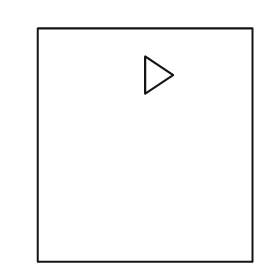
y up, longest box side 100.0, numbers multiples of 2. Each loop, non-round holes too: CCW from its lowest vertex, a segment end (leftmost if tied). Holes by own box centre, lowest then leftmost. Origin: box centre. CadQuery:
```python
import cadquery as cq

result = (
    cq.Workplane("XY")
    .moveTo(-46.0, -50.0)
    .lineTo(46.0, -50.0)
    .lineTo(46.0, 50.0)
    .lineTo(-46.0, 50.0)
    .close()
    .moveTo(0.0, 22.0)
    .lineTo(12.0, 30.0)
    .lineTo(0.0, 38.0)
    .close()
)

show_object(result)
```